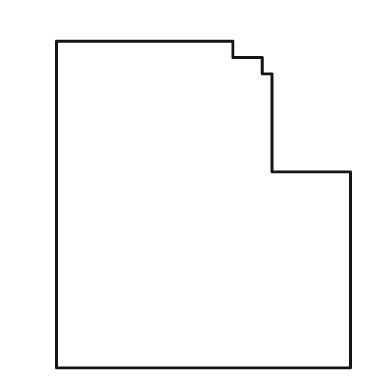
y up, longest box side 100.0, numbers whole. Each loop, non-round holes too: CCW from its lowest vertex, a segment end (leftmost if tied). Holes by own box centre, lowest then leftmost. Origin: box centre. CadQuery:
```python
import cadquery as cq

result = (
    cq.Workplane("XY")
    .moveTo(-45.0, -50.0)
    .lineTo(45.0, -50.0)
    .lineTo(45.0, 10.0)
    .lineTo(21.0, 10.0)
    .lineTo(21.0, 40.0)
    .lineTo(18.0, 40.0)
    .lineTo(18.0, 45.0)
    .lineTo(9.0, 45.0)
    .lineTo(9.0, 50.0)
    .lineTo(-45.0, 50.0)
    .close()
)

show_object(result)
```